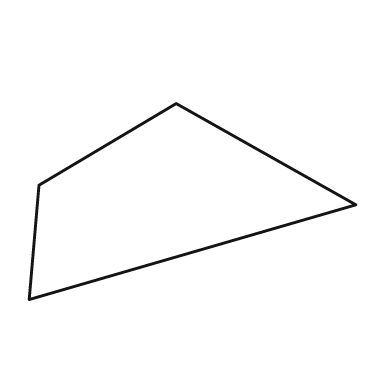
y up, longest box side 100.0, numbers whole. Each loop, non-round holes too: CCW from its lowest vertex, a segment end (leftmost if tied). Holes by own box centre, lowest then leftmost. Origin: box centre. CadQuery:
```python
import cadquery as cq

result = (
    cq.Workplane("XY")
    .moveTo(-50.0, -30.0)
    .lineTo(50.0, -1.0)
    .lineTo(-5.0, 30.0)
    .lineTo(-47.0, 5.0)
    .close()
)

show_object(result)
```